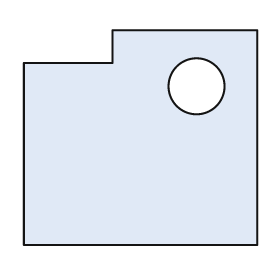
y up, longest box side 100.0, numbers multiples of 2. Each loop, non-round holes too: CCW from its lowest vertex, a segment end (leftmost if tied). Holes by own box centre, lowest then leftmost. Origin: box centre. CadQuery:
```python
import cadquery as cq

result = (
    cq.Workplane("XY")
    .moveTo(-50.0, -46.0)
    .lineTo(50.0, -46.0)
    .lineTo(50.0, 46.0)
    .lineTo(-12.0, 46.0)
    .lineTo(-12.0, 32.0)
    .lineTo(-50.0, 32.0)
    .close()
    .moveTo(24.0, 22.0)
    .circle(12.0)
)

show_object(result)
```